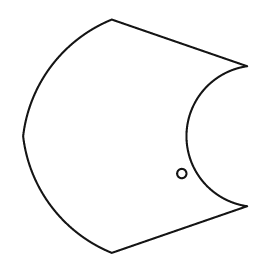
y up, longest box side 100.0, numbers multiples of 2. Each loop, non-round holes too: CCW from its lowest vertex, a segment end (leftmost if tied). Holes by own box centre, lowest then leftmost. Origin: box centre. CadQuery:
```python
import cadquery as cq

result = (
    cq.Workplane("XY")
    .moveTo(-10.0, -50.0)
    .lineTo(48.0, -30.0)
    .threePointArc((22.0, 0.0), (48.0, 30.0))
    .lineTo(-10.0, 50.0)
    .threePointArc((-36.0, 30.0), (-48.0, 0.0))
    .threePointArc((-36.0, -30.0), (-10.0, -50.0))
    .close()
    .moveTo(20.0, -16.0)
    .circle(2.0)
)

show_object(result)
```